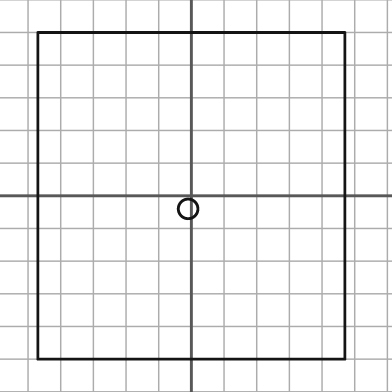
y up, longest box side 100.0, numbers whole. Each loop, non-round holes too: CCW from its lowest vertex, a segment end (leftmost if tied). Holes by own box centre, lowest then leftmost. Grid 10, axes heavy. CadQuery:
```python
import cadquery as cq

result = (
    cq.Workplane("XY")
    .moveTo(-47.0, -50.0)
    .lineTo(47.0, -50.0)
    .lineTo(47.0, 50.0)
    .lineTo(-47.0, 50.0)
    .close()
    .moveTo(-1.0, -4.0)
    .circle(3.0)
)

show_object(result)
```